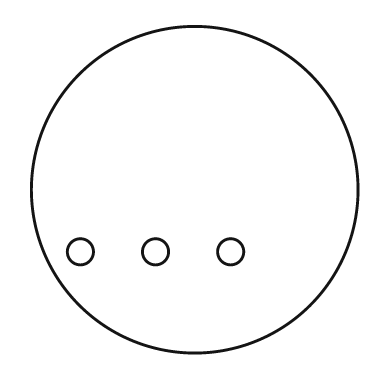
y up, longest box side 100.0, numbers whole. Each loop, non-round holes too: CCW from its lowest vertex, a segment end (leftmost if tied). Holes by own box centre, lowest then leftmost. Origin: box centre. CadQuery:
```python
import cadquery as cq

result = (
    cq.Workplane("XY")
    .moveTo(0.0, 0.0)
    .circle(50.0)
    .moveTo(-35.0, -19.0)
    .circle(4.0)
    .moveTo(-12.0, -19.0)
    .circle(4.0)
    .moveTo(11.0, -19.0)
    .circle(4.0)
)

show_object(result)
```